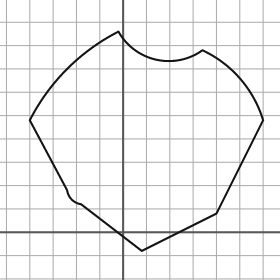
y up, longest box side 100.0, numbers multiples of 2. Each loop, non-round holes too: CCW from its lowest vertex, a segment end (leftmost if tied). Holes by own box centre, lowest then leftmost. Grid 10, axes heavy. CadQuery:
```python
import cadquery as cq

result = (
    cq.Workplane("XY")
    .moveTo(8.0, -8.0)
    .lineTo(40.0, 8.0)
    .lineTo(60.0, 48.0)
    .threePointArc((50.0, 66.0), (34.0, 78.0))
    .threePointArc((14.0, 74.0), (-2.0, 86.0))
    .threePointArc((-24.0, 70.0), (-40.0, 48.0))
    .lineTo(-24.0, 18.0)
    .threePointArc((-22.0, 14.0), (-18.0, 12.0))
    .close()
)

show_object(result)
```